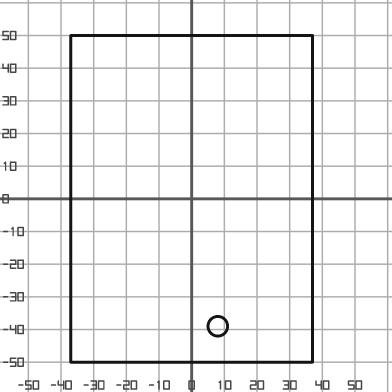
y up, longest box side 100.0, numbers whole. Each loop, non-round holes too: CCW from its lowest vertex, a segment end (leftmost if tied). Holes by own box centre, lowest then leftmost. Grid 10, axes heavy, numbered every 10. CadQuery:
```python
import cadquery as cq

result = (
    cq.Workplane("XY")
    .moveTo(-37.0, -50.0)
    .lineTo(37.0, -50.0)
    .lineTo(37.0, 50.0)
    .lineTo(-37.0, 50.0)
    .close()
    .moveTo(8.0, -39.0)
    .circle(3.0)
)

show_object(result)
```